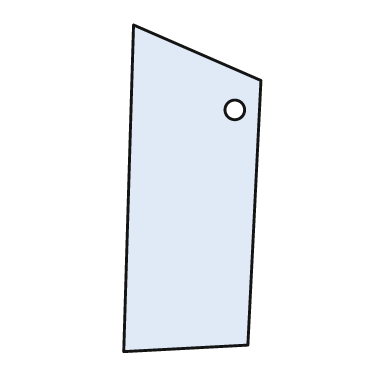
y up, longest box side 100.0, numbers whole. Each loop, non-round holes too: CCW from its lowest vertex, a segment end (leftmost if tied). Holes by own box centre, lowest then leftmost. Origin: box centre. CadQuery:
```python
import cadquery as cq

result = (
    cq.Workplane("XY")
    .moveTo(-21.0, -50.0)
    .lineTo(17.0, -48.0)
    .lineTo(21.0, 33.0)
    .lineTo(-18.0, 50.0)
    .close()
    .moveTo(13.0, 24.0)
    .circle(3.0)
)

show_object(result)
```